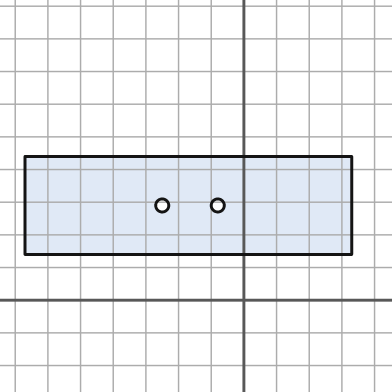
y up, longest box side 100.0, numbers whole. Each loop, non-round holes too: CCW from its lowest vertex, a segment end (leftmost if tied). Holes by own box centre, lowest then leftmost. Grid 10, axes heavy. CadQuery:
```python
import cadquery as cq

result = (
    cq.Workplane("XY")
    .moveTo(-67.0, 14.0)
    .lineTo(33.0, 14.0)
    .lineTo(33.0, 44.0)
    .lineTo(-67.0, 44.0)
    .close()
    .moveTo(-25.0, 29.0)
    .circle(2.0)
    .moveTo(-8.0, 29.0)
    .circle(2.0)
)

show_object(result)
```